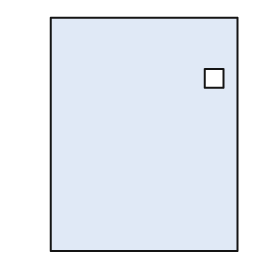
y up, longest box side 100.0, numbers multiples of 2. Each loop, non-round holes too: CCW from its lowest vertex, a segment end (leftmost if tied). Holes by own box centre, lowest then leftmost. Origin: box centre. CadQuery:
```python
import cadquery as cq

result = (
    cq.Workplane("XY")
    .moveTo(-40.0, -50.0)
    .lineTo(40.0, -50.0)
    .lineTo(40.0, 50.0)
    .lineTo(-40.0, 50.0)
    .close()
    .moveTo(26.0, 20.0)
    .lineTo(34.0, 20.0)
    .lineTo(34.0, 28.0)
    .lineTo(26.0, 28.0)
    .close()
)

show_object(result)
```